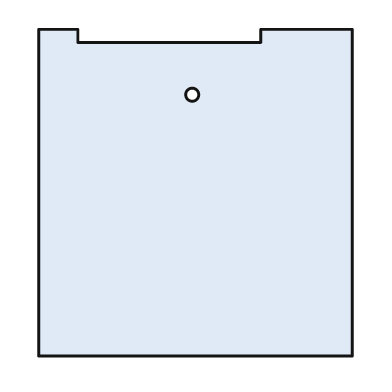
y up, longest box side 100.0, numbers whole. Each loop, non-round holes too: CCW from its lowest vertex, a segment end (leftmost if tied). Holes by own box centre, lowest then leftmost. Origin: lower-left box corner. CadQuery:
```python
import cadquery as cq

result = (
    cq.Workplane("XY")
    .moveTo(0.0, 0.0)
    .lineTo(96.0, 0.0)
    .lineTo(96.0, 100.0)
    .lineTo(68.0, 100.0)
    .lineTo(68.0, 96.0)
    .lineTo(12.0, 96.0)
    .lineTo(12.0, 100.0)
    .lineTo(0.0, 100.0)
    .close()
    .moveTo(47.0, 80.0)
    .circle(2.0)
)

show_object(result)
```